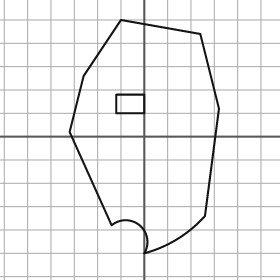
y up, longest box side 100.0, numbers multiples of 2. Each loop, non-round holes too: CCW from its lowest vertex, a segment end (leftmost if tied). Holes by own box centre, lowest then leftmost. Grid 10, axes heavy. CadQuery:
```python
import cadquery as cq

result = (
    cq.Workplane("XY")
    .moveTo(0.0, -50.0)
    .threePointArc((14.0, -44.0), (26.0, -34.0))
    .lineTo(32.0, 12.0)
    .lineTo(24.0, 44.0)
    .lineTo(-10.0, 50.0)
    .lineTo(-26.0, 26.0)
    .lineTo(-32.0, 2.0)
    .lineTo(-14.0, -38.0)
    .threePointArc((-2.0, -38.0), (0.0, -50.0))
    .close()
    .moveTo(-12.0, 10.0)
    .lineTo(0.0, 10.0)
    .lineTo(0.0, 18.0)
    .lineTo(-12.0, 18.0)
    .close()
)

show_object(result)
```